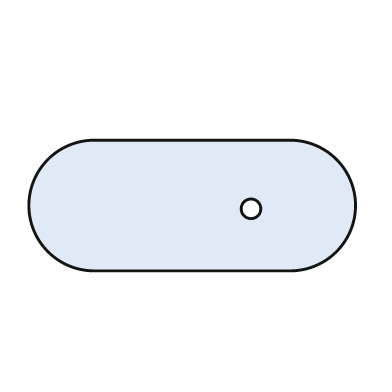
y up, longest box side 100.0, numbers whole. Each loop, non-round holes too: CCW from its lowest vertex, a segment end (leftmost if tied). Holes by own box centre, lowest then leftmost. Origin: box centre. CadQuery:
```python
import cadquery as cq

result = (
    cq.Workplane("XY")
    .moveTo(-30.0, -20.0)
    .lineTo(30.0, -20.0)
    .threePointArc((50.0, 0.0), (30.0, 20.0))
    .lineTo(-30.0, 20.0)
    .threePointArc((-50.0, 0.0), (-30.0, -20.0))
    .close()
    .moveTo(18.0, -1.0)
    .circle(3.0)
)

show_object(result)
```